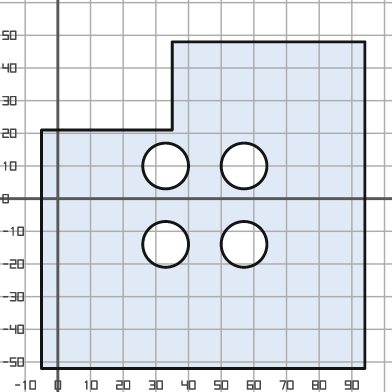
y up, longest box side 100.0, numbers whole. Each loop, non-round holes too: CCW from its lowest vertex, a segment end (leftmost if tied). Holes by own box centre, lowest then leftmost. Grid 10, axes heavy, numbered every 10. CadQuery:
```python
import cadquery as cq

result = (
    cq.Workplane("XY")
    .moveTo(-5.0, -52.0)
    .lineTo(94.0, -52.0)
    .lineTo(94.0, 48.0)
    .lineTo(35.0, 48.0)
    .lineTo(35.0, 21.0)
    .lineTo(-5.0, 21.0)
    .close()
    .moveTo(33.0, -14.0)
    .circle(7.0)
    .moveTo(57.0, -14.0)
    .circle(7.0)
    .moveTo(33.0, 10.0)
    .circle(7.0)
    .moveTo(57.0, 10.0)
    .circle(7.0)
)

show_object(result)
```